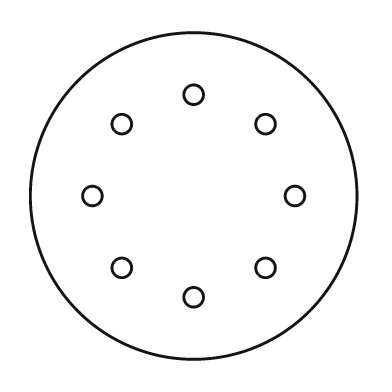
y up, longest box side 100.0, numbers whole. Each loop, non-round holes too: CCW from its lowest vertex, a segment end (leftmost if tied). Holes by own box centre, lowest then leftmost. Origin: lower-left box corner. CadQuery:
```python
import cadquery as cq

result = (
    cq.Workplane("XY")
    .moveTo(50.0, 50.0)
    .circle(50.0)
    .moveTo(50.0, 19.0)
    .circle(3.0)
    .moveTo(28.0, 28.0)
    .circle(3.0)
    .moveTo(72.0, 28.0)
    .circle(3.0)
    .moveTo(19.0, 50.0)
    .circle(3.0)
    .moveTo(81.0, 50.0)
    .circle(3.0)
    .moveTo(28.0, 72.0)
    .circle(3.0)
    .moveTo(72.0, 72.0)
    .circle(3.0)
    .moveTo(50.0, 81.0)
    .circle(3.0)
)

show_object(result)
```